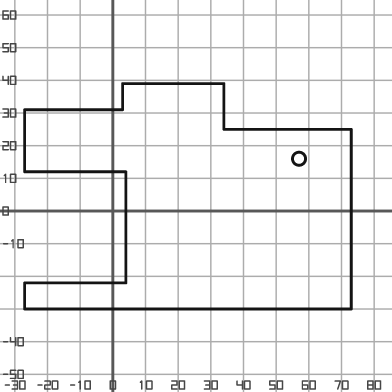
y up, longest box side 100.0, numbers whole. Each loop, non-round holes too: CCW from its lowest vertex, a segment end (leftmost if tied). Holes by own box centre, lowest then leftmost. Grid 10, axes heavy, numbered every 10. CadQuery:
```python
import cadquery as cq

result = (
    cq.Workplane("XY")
    .moveTo(-27.0, -30.0)
    .lineTo(73.0, -30.0)
    .lineTo(73.0, 25.0)
    .lineTo(34.0, 25.0)
    .lineTo(34.0, 39.0)
    .lineTo(3.0, 39.0)
    .lineTo(3.0, 31.0)
    .lineTo(-27.0, 31.0)
    .lineTo(-27.0, 12.0)
    .lineTo(4.0, 12.0)
    .lineTo(4.0, -22.0)
    .lineTo(-27.0, -22.0)
    .close()
    .moveTo(57.0, 16.0)
    .circle(2.0)
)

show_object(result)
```